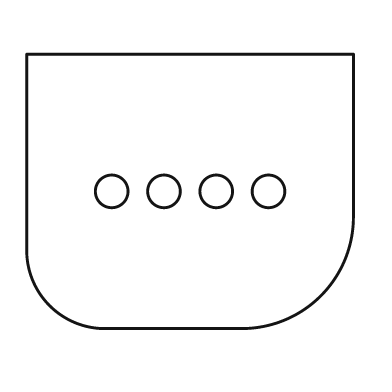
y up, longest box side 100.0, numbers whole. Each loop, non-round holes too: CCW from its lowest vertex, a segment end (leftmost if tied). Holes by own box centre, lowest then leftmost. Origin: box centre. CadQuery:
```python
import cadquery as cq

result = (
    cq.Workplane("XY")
    .moveTo(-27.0, -42.0)
    .lineTo(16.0, -42.0)
    .threePointArc((40.0, -32.0), (50.0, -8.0))
    .lineTo(50.0, 42.0)
    .lineTo(-50.0, 42.0)
    .lineTo(-50.0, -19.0)
    .threePointArc((-43.0, -35.0), (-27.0, -42.0))
    .close()
    .moveTo(-24.0, 0.0)
    .circle(5.0)
    .moveTo(-8.0, 0.0)
    .circle(5.0)
    .moveTo(8.0, 0.0)
    .circle(5.0)
    .moveTo(24.0, 0.0)
    .circle(5.0)
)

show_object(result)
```